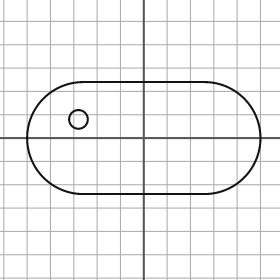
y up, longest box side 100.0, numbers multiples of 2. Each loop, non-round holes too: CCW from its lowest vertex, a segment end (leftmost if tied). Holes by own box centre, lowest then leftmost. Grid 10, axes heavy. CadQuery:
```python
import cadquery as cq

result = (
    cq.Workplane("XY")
    .moveTo(-26.0, -24.0)
    .lineTo(26.0, -24.0)
    .threePointArc((50.0, 0.0), (26.0, 24.0))
    .lineTo(-26.0, 24.0)
    .threePointArc((-50.0, 0.0), (-26.0, -24.0))
    .close()
    .moveTo(-28.0, 8.0)
    .circle(4.0)
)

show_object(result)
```